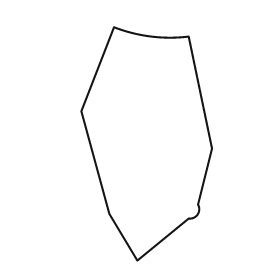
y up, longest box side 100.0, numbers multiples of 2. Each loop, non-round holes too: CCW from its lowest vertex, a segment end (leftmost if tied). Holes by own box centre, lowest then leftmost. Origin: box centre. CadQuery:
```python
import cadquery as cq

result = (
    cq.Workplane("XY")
    .moveTo(-4.0, -50.0)
    .lineTo(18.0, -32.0)
    .threePointArc((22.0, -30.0), (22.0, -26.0))
    .lineTo(28.0, -2.0)
    .lineTo(18.0, 46.0)
    .threePointArc((2.0, 46.0), (-14.0, 50.0))
    .lineTo(-28.0, 14.0)
    .lineTo(-16.0, -30.0)
    .close()
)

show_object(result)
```